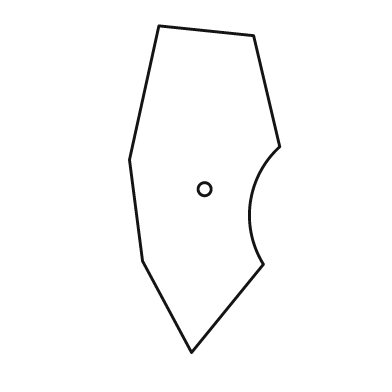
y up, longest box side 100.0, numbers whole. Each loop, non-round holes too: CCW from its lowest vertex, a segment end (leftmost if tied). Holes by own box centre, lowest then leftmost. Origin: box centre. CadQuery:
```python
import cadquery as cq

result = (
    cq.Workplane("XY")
    .moveTo(-4.0, -50.0)
    .lineTo(18.0, -23.0)
    .threePointArc((14.0, -4.0), (23.0, 13.0))
    .lineTo(15.0, 47.0)
    .lineTo(-14.0, 50.0)
    .lineTo(-23.0, 9.0)
    .lineTo(-19.0, -22.0)
    .close()
    .moveTo(0.0, 0.0)
    .circle(2.0)
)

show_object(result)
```